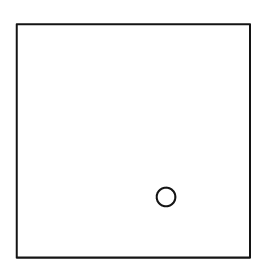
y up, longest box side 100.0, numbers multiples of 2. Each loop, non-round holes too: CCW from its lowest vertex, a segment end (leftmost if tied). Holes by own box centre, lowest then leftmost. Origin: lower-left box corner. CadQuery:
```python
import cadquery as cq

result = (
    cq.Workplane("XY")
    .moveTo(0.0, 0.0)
    .lineTo(100.0, 0.0)
    .lineTo(100.0, 100.0)
    .lineTo(0.0, 100.0)
    .close()
    .moveTo(64.0, 26.0)
    .circle(4.0)
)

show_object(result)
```